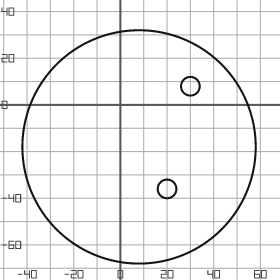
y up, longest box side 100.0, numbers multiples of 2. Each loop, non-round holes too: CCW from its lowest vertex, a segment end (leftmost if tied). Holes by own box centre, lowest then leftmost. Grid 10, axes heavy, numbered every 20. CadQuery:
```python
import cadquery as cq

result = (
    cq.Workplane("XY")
    .moveTo(8.0, -18.0)
    .circle(50.0)
    .moveTo(20.0, -36.0)
    .circle(4.0)
    .moveTo(30.0, 8.0)
    .circle(4.0)
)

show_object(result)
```